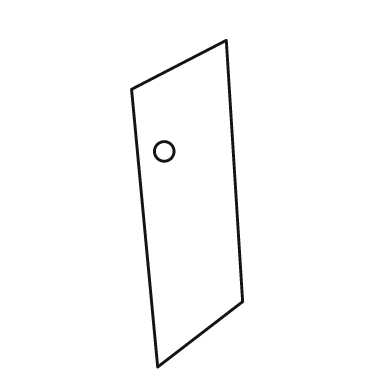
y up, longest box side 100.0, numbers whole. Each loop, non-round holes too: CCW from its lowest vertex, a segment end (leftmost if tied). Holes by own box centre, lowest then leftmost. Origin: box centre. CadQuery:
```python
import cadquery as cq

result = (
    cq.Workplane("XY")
    .moveTo(-9.0, -50.0)
    .lineTo(17.0, -30.0)
    .lineTo(12.0, 50.0)
    .lineTo(-17.0, 35.0)
    .close()
    .moveTo(-7.0, 16.0)
    .circle(3.0)
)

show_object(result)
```